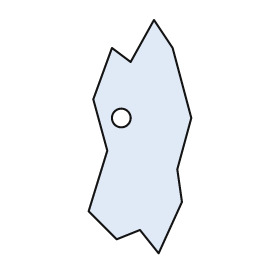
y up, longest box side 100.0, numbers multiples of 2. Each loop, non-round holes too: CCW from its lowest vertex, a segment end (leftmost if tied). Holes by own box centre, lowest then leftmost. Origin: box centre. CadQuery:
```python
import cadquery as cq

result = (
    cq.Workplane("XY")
    .moveTo(8.0, -50.0)
    .lineTo(18.0, -28.0)
    .lineTo(16.0, -14.0)
    .lineTo(22.0, 8.0)
    .lineTo(14.0, 38.0)
    .lineTo(6.0, 50.0)
    .lineTo(-4.0, 32.0)
    .lineTo(-12.0, 38.0)
    .lineTo(-20.0, 16.0)
    .lineTo(-14.0, -6.0)
    .lineTo(-22.0, -32.0)
    .lineTo(-10.0, -44.0)
    .lineTo(0.0, -40.0)
    .close()
    .moveTo(-8.0, 8.0)
    .circle(4.0)
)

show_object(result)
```